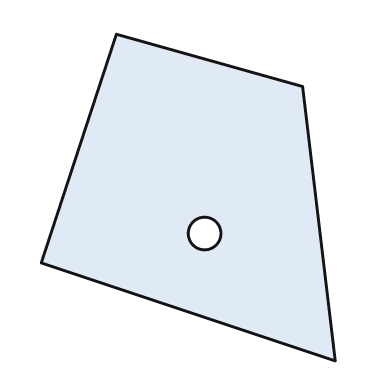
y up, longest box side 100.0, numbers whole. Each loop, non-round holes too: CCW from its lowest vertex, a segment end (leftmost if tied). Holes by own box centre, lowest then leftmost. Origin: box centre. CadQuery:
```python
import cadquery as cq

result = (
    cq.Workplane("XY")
    .moveTo(45.0, -50.0)
    .lineTo(35.0, 34.0)
    .lineTo(-22.0, 50.0)
    .lineTo(-45.0, -20.0)
    .close()
    .moveTo(5.0, -11.0)
    .circle(5.0)
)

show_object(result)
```